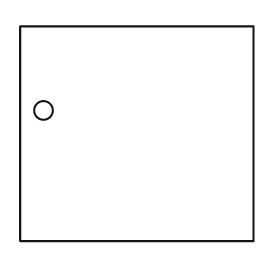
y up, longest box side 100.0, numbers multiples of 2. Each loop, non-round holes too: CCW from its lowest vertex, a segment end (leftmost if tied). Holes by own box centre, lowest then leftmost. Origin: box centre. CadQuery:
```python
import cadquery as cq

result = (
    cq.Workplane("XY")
    .moveTo(-50.0, -46.0)
    .lineTo(50.0, -46.0)
    .lineTo(50.0, 46.0)
    .lineTo(-50.0, 46.0)
    .close()
    .moveTo(-40.0, 10.0)
    .circle(4.0)
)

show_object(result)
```